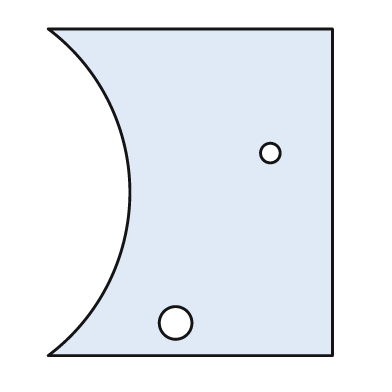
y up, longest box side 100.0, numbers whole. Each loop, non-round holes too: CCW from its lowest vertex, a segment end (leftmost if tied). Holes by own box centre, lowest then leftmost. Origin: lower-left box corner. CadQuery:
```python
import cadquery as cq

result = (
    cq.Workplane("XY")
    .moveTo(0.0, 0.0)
    .lineTo(87.0, 0.0)
    .lineTo(87.0, 100.0)
    .lineTo(0.0, 100.0)
    .threePointArc((25.0, 50.0), (0.0, 0.0))
    .close()
    .moveTo(39.0, 10.0)
    .circle(5.0)
    .moveTo(68.0, 62.0)
    .circle(3.0)
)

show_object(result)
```